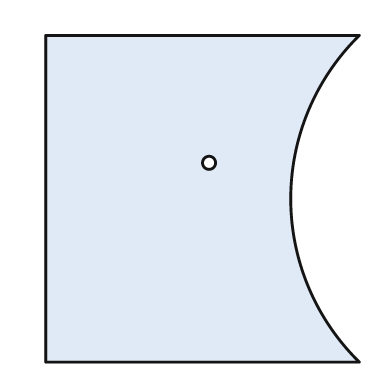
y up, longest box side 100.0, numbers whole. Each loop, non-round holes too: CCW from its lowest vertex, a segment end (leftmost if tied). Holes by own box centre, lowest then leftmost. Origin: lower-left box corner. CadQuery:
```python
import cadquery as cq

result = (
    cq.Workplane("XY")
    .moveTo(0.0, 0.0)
    .lineTo(96.0, 0.0)
    .threePointArc((75.0, 50.0), (96.0, 100.0))
    .lineTo(0.0, 100.0)
    .close()
    .moveTo(50.0, 61.0)
    .circle(2.0)
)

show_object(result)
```